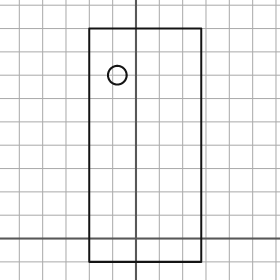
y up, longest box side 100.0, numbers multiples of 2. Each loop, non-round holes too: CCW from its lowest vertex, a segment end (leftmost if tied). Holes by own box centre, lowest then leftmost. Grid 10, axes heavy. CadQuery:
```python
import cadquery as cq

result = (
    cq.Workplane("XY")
    .moveTo(-20.0, -10.0)
    .lineTo(28.0, -10.0)
    .lineTo(28.0, 90.0)
    .lineTo(-20.0, 90.0)
    .close()
    .moveTo(-8.0, 70.0)
    .circle(4.0)
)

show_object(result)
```